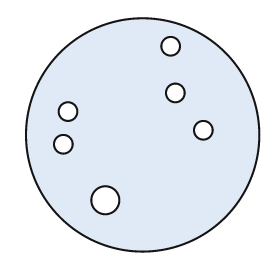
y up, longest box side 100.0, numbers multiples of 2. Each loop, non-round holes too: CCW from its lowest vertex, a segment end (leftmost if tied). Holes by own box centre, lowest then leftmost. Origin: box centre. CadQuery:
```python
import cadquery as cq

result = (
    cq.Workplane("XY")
    .moveTo(0.0, 0.0)
    .circle(50.0)
    .moveTo(-16.0, -28.0)
    .circle(6.0)
    .moveTo(-34.0, -4.0)
    .circle(4.0)
    .moveTo(26.0, 2.0)
    .circle(4.0)
    .moveTo(-32.0, 10.0)
    .circle(4.0)
    .moveTo(14.0, 18.0)
    .circle(4.0)
    .moveTo(12.0, 38.0)
    .circle(4.0)
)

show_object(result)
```